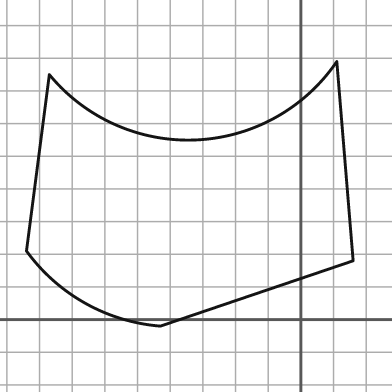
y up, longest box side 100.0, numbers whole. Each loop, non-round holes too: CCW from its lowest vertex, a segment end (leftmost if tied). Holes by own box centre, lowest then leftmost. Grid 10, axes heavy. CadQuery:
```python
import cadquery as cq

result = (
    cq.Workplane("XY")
    .moveTo(-43.0, -2.0)
    .lineTo(16.0, 18.0)
    .lineTo(11.0, 79.0)
    .threePointArc((-32.0, 55.0), (-77.0, 75.0))
    .lineTo(-84.0, 21.0)
    .threePointArc((-66.0, 5.0), (-43.0, -2.0))
    .close()
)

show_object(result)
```